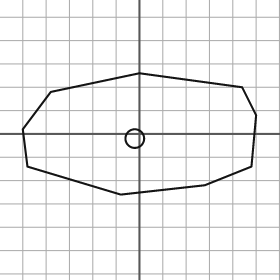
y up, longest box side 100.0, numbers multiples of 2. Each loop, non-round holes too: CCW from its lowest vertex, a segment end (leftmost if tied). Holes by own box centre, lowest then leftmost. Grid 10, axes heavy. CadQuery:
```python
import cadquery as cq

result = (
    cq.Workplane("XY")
    .moveTo(-8.0, -26.0)
    .lineTo(28.0, -22.0)
    .lineTo(48.0, -14.0)
    .lineTo(50.0, 8.0)
    .lineTo(44.0, 20.0)
    .lineTo(0.0, 26.0)
    .lineTo(-38.0, 18.0)
    .lineTo(-50.0, 2.0)
    .lineTo(-48.0, -14.0)
    .close()
    .moveTo(-2.0, -2.0)
    .circle(4.0)
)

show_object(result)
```